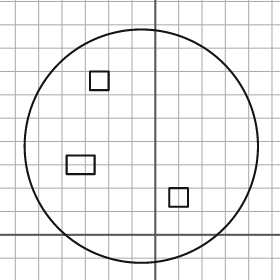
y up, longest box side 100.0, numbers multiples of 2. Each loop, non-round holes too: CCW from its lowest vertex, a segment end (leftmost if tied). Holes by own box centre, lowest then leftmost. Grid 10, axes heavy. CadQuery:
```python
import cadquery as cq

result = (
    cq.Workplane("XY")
    .moveTo(-6.0, 38.0)
    .circle(50.0)
    .moveTo(6.0, 12.0)
    .lineTo(14.0, 12.0)
    .lineTo(14.0, 20.0)
    .lineTo(6.0, 20.0)
    .close()
    .moveTo(-38.0, 26.0)
    .lineTo(-26.0, 26.0)
    .lineTo(-26.0, 34.0)
    .lineTo(-38.0, 34.0)
    .close()
    .moveTo(-28.0, 62.0)
    .lineTo(-20.0, 62.0)
    .lineTo(-20.0, 70.0)
    .lineTo(-28.0, 70.0)
    .close()
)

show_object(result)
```